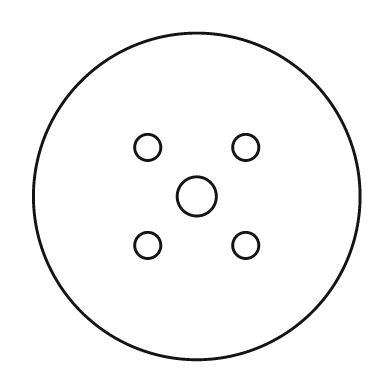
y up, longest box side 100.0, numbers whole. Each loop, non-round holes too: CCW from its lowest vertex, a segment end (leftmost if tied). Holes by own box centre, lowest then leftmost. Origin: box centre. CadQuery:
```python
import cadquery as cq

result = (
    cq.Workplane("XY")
    .moveTo(0.0, 0.0)
    .circle(50.0)
    .moveTo(-15.0, -15.0)
    .circle(4.0)
    .moveTo(15.0, -15.0)
    .circle(4.0)
    .moveTo(0.0, 0.0)
    .circle(6.0)
    .moveTo(-15.0, 15.0)
    .circle(4.0)
    .moveTo(15.0, 15.0)
    .circle(4.0)
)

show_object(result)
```